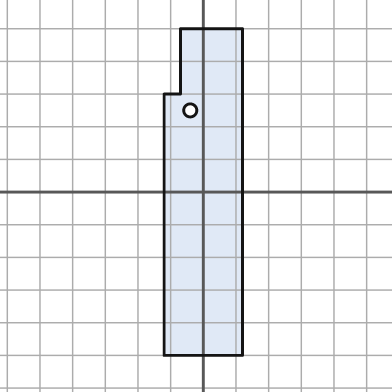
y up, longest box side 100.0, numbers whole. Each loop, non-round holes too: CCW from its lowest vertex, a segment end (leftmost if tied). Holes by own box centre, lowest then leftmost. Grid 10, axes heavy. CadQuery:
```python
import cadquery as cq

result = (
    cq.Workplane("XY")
    .moveTo(-12.0, -50.0)
    .lineTo(12.0, -50.0)
    .lineTo(12.0, 50.0)
    .lineTo(-7.0, 50.0)
    .lineTo(-7.0, 30.0)
    .lineTo(-12.0, 30.0)
    .close()
    .moveTo(-4.0, 25.0)
    .circle(2.0)
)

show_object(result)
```